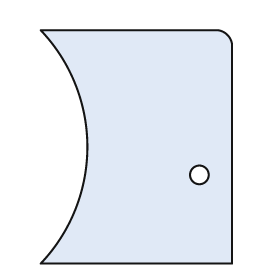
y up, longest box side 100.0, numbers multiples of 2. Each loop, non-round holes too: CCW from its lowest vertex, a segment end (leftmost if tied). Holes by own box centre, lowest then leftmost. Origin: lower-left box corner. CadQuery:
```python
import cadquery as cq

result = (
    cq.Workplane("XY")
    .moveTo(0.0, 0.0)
    .lineTo(82.0, 0.0)
    .lineTo(82.0, 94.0)
    .threePointArc((80.0, 98.0), (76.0, 100.0))
    .lineTo(0.0, 100.0)
    .threePointArc((20.0, 50.0), (0.0, 0.0))
    .close()
    .moveTo(68.0, 38.0)
    .circle(4.0)
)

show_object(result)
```